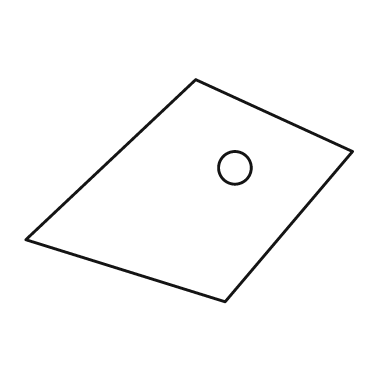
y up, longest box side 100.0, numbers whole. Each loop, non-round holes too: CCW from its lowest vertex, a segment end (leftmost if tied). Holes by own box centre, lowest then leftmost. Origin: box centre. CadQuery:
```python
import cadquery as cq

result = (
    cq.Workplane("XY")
    .moveTo(11.0, -34.0)
    .lineTo(50.0, 12.0)
    .lineTo(2.0, 34.0)
    .lineTo(-50.0, -15.0)
    .close()
    .moveTo(14.0, 7.0)
    .circle(5.0)
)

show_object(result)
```